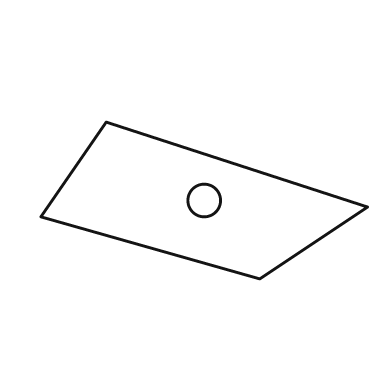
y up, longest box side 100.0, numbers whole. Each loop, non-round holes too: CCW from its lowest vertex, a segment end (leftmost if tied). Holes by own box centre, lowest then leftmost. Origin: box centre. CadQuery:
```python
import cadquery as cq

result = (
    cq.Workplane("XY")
    .moveTo(17.0, -24.0)
    .lineTo(50.0, -2.0)
    .lineTo(-30.0, 24.0)
    .lineTo(-50.0, -5.0)
    .close()
    .moveTo(0.0, 0.0)
    .circle(5.0)
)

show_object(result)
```